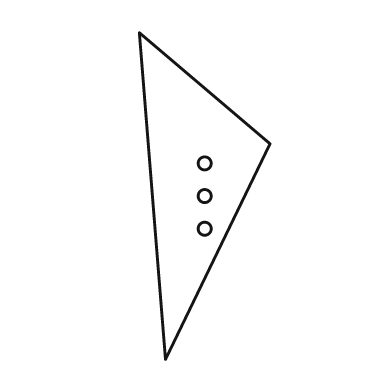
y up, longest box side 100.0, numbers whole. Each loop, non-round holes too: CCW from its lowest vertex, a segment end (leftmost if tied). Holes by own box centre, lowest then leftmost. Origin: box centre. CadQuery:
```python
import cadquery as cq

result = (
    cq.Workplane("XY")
    .moveTo(-12.0, -50.0)
    .lineTo(20.0, 16.0)
    .lineTo(-20.0, 50.0)
    .close()
    .moveTo(0.0, -10.0)
    .circle(2.0)
    .moveTo(0.0, 0.0)
    .circle(2.0)
    .moveTo(0.0, 10.0)
    .circle(2.0)
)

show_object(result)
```